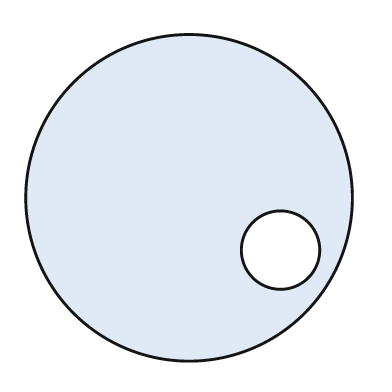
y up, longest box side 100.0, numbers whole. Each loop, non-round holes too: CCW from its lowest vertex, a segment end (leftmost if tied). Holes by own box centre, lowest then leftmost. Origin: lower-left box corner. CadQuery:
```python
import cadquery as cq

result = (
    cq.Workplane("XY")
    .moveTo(50.0, 50.0)
    .circle(50.0)
    .moveTo(78.0, 34.0)
    .circle(12.0)
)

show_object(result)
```